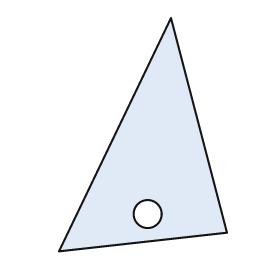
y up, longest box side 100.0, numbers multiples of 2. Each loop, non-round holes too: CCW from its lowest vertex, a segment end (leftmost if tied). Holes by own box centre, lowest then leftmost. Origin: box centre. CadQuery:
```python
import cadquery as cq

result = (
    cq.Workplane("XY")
    .moveTo(-36.0, -50.0)
    .lineTo(36.0, -42.0)
    .lineTo(12.0, 50.0)
    .close()
    .moveTo(2.0, -34.0)
    .circle(6.0)
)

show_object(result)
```